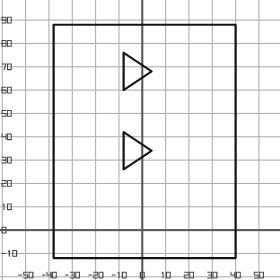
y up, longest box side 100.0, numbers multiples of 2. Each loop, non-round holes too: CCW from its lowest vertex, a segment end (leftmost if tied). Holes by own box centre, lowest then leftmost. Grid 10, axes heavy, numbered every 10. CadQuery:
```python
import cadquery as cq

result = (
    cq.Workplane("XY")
    .moveTo(-38.0, -12.0)
    .lineTo(40.0, -12.0)
    .lineTo(40.0, 88.0)
    .lineTo(-38.0, 88.0)
    .close()
    .moveTo(-8.0, 26.0)
    .lineTo(4.0, 34.0)
    .lineTo(-8.0, 42.0)
    .close()
    .moveTo(-8.0, 60.0)
    .lineTo(4.0, 68.0)
    .lineTo(-8.0, 76.0)
    .close()
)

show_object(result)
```